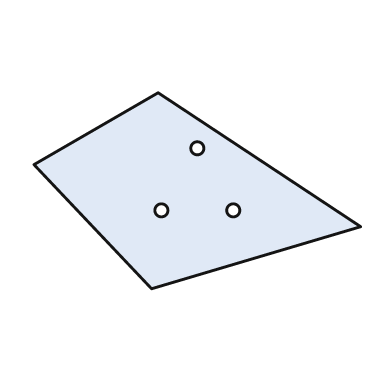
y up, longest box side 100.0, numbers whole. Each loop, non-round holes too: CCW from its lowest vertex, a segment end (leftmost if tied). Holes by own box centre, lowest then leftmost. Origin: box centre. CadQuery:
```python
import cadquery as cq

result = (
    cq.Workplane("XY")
    .moveTo(-14.0, -30.0)
    .lineTo(50.0, -11.0)
    .lineTo(-12.0, 30.0)
    .lineTo(-50.0, 8.0)
    .close()
    .moveTo(-11.0, -6.0)
    .circle(2.0)
    .moveTo(11.0, -6.0)
    .circle(2.0)
    .moveTo(0.0, 13.0)
    .circle(2.0)
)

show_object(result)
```